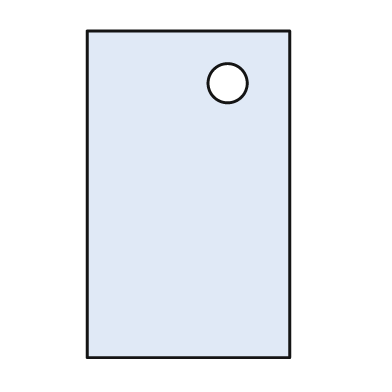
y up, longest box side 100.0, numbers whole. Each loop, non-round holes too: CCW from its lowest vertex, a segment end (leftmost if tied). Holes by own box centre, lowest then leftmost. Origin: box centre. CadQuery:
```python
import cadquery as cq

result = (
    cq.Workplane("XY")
    .moveTo(-31.0, -50.0)
    .lineTo(31.0, -50.0)
    .lineTo(31.0, 50.0)
    .lineTo(-31.0, 50.0)
    .close()
    .moveTo(12.0, 34.0)
    .circle(6.0)
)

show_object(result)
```